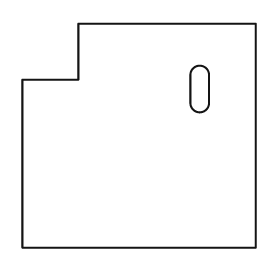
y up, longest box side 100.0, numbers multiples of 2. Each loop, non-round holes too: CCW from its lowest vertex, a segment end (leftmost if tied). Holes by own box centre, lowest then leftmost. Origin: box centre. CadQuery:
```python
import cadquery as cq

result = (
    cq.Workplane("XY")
    .moveTo(-50.0, -48.0)
    .lineTo(50.0, -48.0)
    .lineTo(50.0, 48.0)
    .lineTo(-26.0, 48.0)
    .lineTo(-26.0, 24.0)
    .lineTo(-50.0, 24.0)
    .close()
    .moveTo(22.0, 14.0)
    .threePointArc((26.0, 10.0), (30.0, 14.0))
    .lineTo(30.0, 26.0)
    .threePointArc((26.0, 30.0), (22.0, 26.0))
    .close()
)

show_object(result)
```